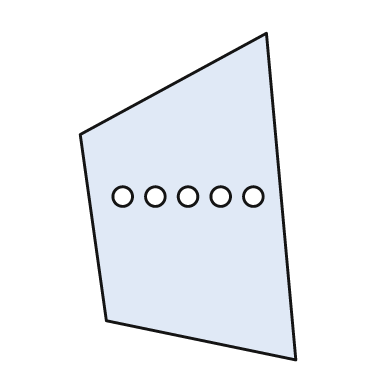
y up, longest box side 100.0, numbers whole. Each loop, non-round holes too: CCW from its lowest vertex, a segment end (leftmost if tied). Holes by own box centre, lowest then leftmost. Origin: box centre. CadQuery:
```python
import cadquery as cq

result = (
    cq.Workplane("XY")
    .moveTo(33.0, -50.0)
    .lineTo(24.0, 50.0)
    .lineTo(-33.0, 19.0)
    .lineTo(-25.0, -38.0)
    .close()
    .moveTo(-20.0, 0.0)
    .circle(3.0)
    .moveTo(-10.0, 0.0)
    .circle(3.0)
    .moveTo(0.0, 0.0)
    .circle(3.0)
    .moveTo(10.0, 0.0)
    .circle(3.0)
    .moveTo(20.0, 0.0)
    .circle(3.0)
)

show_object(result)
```